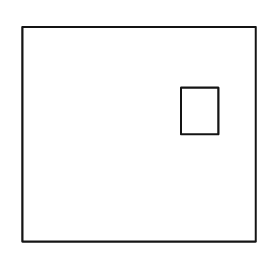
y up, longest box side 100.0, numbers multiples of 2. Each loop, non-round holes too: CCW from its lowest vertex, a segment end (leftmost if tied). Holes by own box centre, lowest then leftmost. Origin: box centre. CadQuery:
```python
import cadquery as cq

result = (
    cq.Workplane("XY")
    .moveTo(-50.0, -46.0)
    .lineTo(50.0, -46.0)
    .lineTo(50.0, 46.0)
    .lineTo(-50.0, 46.0)
    .close()
    .moveTo(18.0, 0.0)
    .lineTo(34.0, 0.0)
    .lineTo(34.0, 20.0)
    .lineTo(18.0, 20.0)
    .close()
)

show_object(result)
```